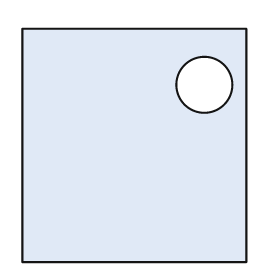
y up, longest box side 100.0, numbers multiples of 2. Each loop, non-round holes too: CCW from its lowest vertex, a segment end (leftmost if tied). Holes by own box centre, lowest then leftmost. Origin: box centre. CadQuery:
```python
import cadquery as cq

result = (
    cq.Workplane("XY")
    .moveTo(-48.0, -50.0)
    .lineTo(48.0, -50.0)
    .lineTo(48.0, 50.0)
    .lineTo(-48.0, 50.0)
    .close()
    .moveTo(30.0, 26.0)
    .circle(12.0)
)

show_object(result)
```